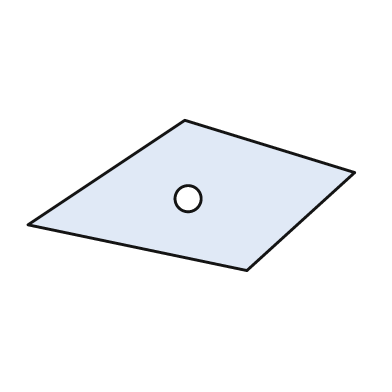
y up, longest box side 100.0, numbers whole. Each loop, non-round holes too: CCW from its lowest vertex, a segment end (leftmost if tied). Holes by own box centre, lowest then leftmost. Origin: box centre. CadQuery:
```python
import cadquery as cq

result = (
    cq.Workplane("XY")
    .moveTo(17.0, -23.0)
    .lineTo(50.0, 7.0)
    .lineTo(-2.0, 23.0)
    .lineTo(-50.0, -9.0)
    .close()
    .moveTo(-1.0, -1.0)
    .circle(4.0)
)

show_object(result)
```